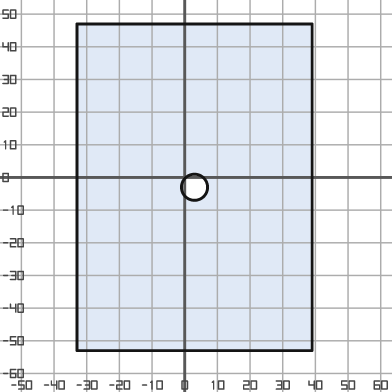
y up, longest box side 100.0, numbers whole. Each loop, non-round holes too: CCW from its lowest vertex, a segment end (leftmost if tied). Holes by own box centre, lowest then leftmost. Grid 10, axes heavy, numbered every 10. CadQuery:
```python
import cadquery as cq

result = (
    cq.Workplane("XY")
    .moveTo(-33.0, -53.0)
    .lineTo(39.0, -53.0)
    .lineTo(39.0, 47.0)
    .lineTo(-33.0, 47.0)
    .close()
    .moveTo(3.0, -3.0)
    .circle(4.0)
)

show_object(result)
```